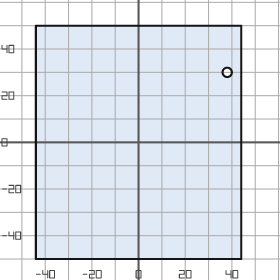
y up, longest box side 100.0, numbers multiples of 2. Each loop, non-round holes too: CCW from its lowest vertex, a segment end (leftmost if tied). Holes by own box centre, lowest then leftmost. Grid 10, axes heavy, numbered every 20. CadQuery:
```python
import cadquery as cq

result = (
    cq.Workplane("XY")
    .moveTo(-44.0, -50.0)
    .lineTo(44.0, -50.0)
    .lineTo(44.0, 50.0)
    .lineTo(-44.0, 50.0)
    .close()
    .moveTo(38.0, 30.0)
    .circle(2.0)
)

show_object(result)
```